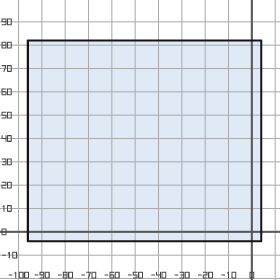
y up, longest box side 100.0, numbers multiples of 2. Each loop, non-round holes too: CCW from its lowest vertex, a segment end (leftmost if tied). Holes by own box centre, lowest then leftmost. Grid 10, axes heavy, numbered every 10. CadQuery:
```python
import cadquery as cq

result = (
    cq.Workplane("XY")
    .moveTo(-96.0, -4.0)
    .lineTo(4.0, -4.0)
    .lineTo(4.0, 82.0)
    .lineTo(-96.0, 82.0)
    .close()
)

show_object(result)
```